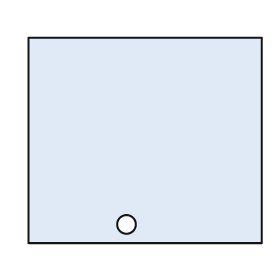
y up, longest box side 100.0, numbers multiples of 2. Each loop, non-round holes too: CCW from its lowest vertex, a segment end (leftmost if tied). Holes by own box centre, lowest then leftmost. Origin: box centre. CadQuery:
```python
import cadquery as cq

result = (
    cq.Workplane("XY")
    .moveTo(-50.0, -44.0)
    .lineTo(50.0, -44.0)
    .lineTo(50.0, 44.0)
    .lineTo(-50.0, 44.0)
    .close()
    .moveTo(-8.0, -36.0)
    .circle(4.0)
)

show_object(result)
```